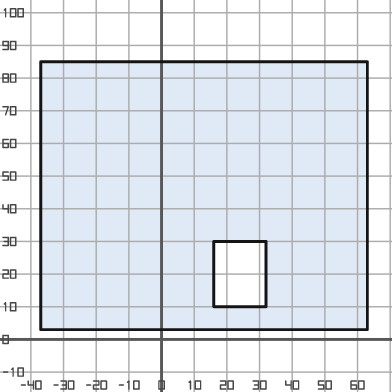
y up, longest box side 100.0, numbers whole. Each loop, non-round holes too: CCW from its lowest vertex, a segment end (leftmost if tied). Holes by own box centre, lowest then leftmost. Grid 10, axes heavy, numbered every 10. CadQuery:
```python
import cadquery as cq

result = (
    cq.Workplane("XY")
    .moveTo(-37.0, 3.0)
    .lineTo(63.0, 3.0)
    .lineTo(63.0, 85.0)
    .lineTo(-37.0, 85.0)
    .close()
    .moveTo(16.0, 10.0)
    .lineTo(32.0, 10.0)
    .lineTo(32.0, 30.0)
    .lineTo(16.0, 30.0)
    .close()
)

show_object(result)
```